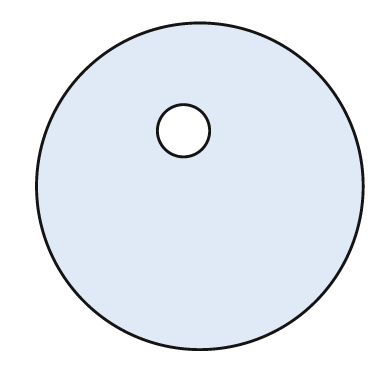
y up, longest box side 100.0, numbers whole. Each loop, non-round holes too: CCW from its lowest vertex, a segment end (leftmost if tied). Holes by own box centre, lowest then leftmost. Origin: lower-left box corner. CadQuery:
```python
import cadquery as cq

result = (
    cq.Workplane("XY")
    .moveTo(50.0, 50.0)
    .circle(50.0)
    .moveTo(45.0, 67.0)
    .circle(8.0)
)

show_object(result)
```